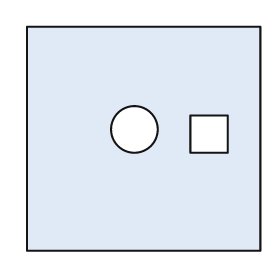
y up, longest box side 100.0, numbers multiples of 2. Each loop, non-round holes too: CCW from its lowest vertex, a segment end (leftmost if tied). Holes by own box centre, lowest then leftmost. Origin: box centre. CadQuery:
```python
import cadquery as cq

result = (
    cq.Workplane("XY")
    .moveTo(-50.0, -48.0)
    .lineTo(50.0, -48.0)
    .lineTo(50.0, 48.0)
    .lineTo(-50.0, 48.0)
    .close()
    .moveTo(20.0, -6.0)
    .lineTo(36.0, -6.0)
    .lineTo(36.0, 10.0)
    .lineTo(20.0, 10.0)
    .close()
    .moveTo(-4.0, 4.0)
    .circle(10.0)
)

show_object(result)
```